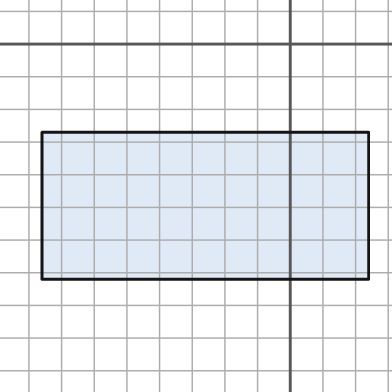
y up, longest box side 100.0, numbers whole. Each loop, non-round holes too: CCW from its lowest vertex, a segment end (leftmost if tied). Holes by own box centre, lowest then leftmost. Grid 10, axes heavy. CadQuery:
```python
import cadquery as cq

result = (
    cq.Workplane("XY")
    .moveTo(-76.0, -72.0)
    .lineTo(24.0, -72.0)
    .lineTo(24.0, -27.0)
    .lineTo(-76.0, -27.0)
    .close()
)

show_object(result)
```